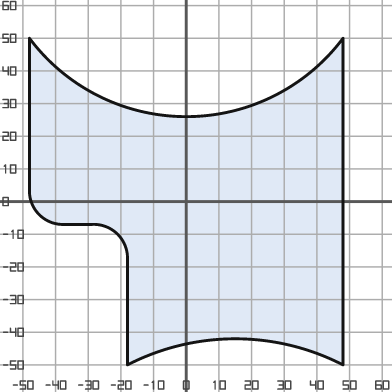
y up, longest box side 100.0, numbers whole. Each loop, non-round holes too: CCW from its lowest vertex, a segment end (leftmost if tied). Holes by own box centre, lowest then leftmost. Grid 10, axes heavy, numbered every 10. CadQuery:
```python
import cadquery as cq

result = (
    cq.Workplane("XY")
    .moveTo(-18.0, -50.0)
    .threePointArc((15.0, -42.0), (48.0, -50.0))
    .lineTo(48.0, 50.0)
    .threePointArc((0.0, 26.0), (-48.0, 50.0))
    .lineTo(-48.0, 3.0)
    .threePointArc((-45.0, -4.0), (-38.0, -7.0))
    .lineTo(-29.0, -7.0)
    .threePointArc((-21.0, -10.0), (-18.0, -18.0))
    .close()
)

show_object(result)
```